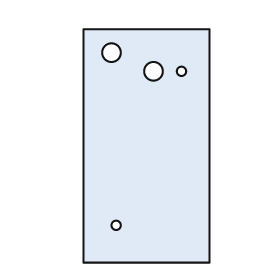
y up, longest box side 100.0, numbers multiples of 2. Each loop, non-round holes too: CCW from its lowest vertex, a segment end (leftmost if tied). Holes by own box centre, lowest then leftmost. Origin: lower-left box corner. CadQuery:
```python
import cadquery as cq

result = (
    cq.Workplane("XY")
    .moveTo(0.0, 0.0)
    .lineTo(54.0, 0.0)
    .lineTo(54.0, 100.0)
    .lineTo(0.0, 100.0)
    .close()
    .moveTo(14.0, 16.0)
    .circle(2.0)
    .moveTo(30.0, 82.0)
    .circle(4.0)
    .moveTo(42.0, 82.0)
    .circle(2.0)
    .moveTo(12.0, 90.0)
    .circle(4.0)
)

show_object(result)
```